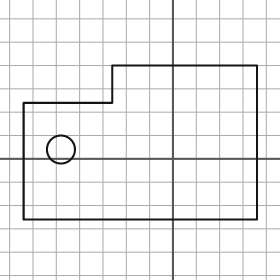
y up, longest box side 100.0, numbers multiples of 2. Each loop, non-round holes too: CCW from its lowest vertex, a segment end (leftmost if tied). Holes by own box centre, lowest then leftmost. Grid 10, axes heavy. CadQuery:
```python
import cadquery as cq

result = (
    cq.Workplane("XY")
    .moveTo(-64.0, -26.0)
    .lineTo(36.0, -26.0)
    .lineTo(36.0, 40.0)
    .lineTo(-26.0, 40.0)
    .lineTo(-26.0, 24.0)
    .lineTo(-64.0, 24.0)
    .close()
    .moveTo(-48.0, 4.0)
    .circle(6.0)
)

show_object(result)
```